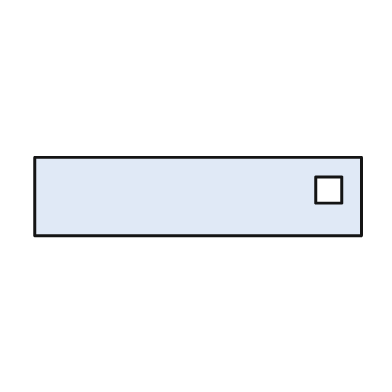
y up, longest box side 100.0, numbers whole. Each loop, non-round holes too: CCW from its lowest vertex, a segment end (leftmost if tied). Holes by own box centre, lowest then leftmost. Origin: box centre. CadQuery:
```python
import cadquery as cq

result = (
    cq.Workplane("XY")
    .moveTo(-50.0, -12.0)
    .lineTo(50.0, -12.0)
    .lineTo(50.0, 12.0)
    .lineTo(-50.0, 12.0)
    .close()
    .moveTo(36.0, -2.0)
    .lineTo(44.0, -2.0)
    .lineTo(44.0, 6.0)
    .lineTo(36.0, 6.0)
    .close()
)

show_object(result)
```